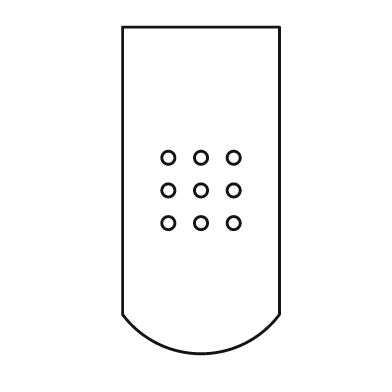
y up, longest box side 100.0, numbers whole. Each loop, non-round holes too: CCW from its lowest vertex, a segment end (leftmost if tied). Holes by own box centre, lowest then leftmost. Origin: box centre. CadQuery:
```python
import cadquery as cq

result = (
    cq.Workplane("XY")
    .moveTo(-24.0, -38.0)
    .threePointArc((0.0, -50.0), (24.0, -38.0))
    .lineTo(24.0, 50.0)
    .lineTo(-24.0, 50.0)
    .close()
    .moveTo(-10.0, -10.0)
    .circle(2.0)
    .moveTo(0.0, -10.0)
    .circle(2.0)
    .moveTo(10.0, -10.0)
    .circle(2.0)
    .moveTo(-10.0, 0.0)
    .circle(2.0)
    .moveTo(0.0, 0.0)
    .circle(2.0)
    .moveTo(10.0, 0.0)
    .circle(2.0)
    .moveTo(-10.0, 10.0)
    .circle(2.0)
    .moveTo(0.0, 10.0)
    .circle(2.0)
    .moveTo(10.0, 10.0)
    .circle(2.0)
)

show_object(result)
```